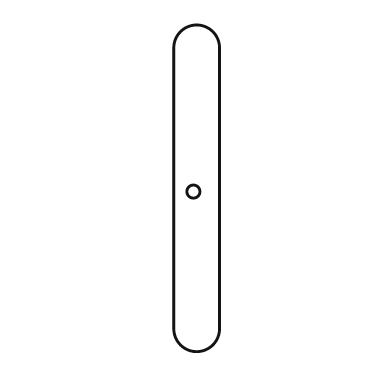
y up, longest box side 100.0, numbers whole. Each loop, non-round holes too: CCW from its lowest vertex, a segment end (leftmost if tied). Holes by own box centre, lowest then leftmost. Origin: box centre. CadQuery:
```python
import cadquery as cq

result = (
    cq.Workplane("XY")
    .moveTo(-7.0, -43.0)
    .threePointArc((0.0, -50.0), (7.0, -43.0))
    .lineTo(7.0, 43.0)
    .threePointArc((0.0, 50.0), (-7.0, 43.0))
    .close()
    .moveTo(-1.0, -1.0)
    .circle(2.0)
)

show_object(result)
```